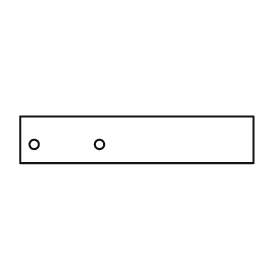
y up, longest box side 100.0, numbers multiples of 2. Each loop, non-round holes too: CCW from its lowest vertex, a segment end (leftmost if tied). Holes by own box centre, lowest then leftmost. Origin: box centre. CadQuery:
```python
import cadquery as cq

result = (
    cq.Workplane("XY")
    .moveTo(-50.0, -10.0)
    .lineTo(50.0, -10.0)
    .lineTo(50.0, 10.0)
    .lineTo(-50.0, 10.0)
    .close()
    .moveTo(-44.0, -2.0)
    .circle(2.0)
    .moveTo(-16.0, -2.0)
    .circle(2.0)
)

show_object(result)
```